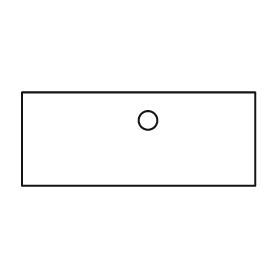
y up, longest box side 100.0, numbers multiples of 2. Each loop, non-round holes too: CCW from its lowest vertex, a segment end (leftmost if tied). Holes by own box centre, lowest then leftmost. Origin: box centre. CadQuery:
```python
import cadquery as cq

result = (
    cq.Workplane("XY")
    .moveTo(-50.0, -20.0)
    .lineTo(50.0, -20.0)
    .lineTo(50.0, 20.0)
    .lineTo(-50.0, 20.0)
    .close()
    .moveTo(4.0, 8.0)
    .circle(4.0)
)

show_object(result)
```